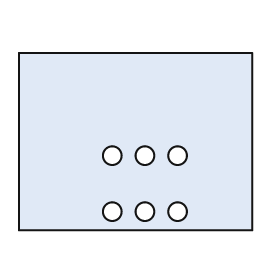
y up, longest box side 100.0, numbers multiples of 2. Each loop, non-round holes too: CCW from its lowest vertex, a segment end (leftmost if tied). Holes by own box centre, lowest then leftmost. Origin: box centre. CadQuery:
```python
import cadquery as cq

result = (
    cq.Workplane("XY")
    .moveTo(-50.0, -38.0)
    .lineTo(50.0, -38.0)
    .lineTo(50.0, 38.0)
    .lineTo(-50.0, 38.0)
    .close()
    .moveTo(-10.0, -30.0)
    .circle(4.0)
    .moveTo(4.0, -30.0)
    .circle(4.0)
    .moveTo(18.0, -30.0)
    .circle(4.0)
    .moveTo(-10.0, -6.0)
    .circle(4.0)
    .moveTo(4.0, -6.0)
    .circle(4.0)
    .moveTo(18.0, -6.0)
    .circle(4.0)
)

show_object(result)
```